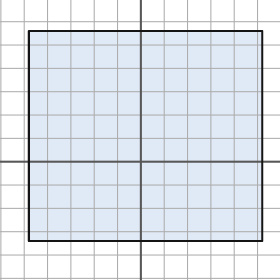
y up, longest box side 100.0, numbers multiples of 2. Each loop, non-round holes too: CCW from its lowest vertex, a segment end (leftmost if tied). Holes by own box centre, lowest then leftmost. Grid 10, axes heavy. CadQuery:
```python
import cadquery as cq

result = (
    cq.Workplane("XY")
    .moveTo(-48.0, -34.0)
    .lineTo(52.0, -34.0)
    .lineTo(52.0, 56.0)
    .lineTo(-48.0, 56.0)
    .close()
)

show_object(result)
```